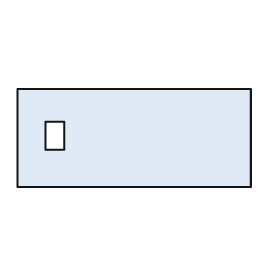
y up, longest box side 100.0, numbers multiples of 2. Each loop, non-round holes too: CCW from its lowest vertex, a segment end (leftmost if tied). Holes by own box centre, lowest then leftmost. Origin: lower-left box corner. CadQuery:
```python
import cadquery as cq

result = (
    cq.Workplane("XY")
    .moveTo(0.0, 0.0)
    .lineTo(100.0, 0.0)
    .lineTo(100.0, 42.0)
    .lineTo(0.0, 42.0)
    .close()
    .moveTo(12.0, 16.0)
    .lineTo(20.0, 16.0)
    .lineTo(20.0, 28.0)
    .lineTo(12.0, 28.0)
    .close()
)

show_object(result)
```